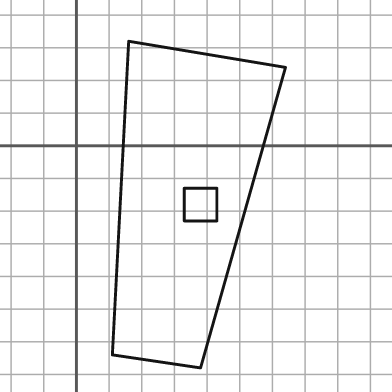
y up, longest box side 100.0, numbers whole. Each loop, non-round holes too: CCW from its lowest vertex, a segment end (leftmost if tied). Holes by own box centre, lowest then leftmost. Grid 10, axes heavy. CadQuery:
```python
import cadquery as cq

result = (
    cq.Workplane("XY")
    .moveTo(38.0, -68.0)
    .lineTo(64.0, 24.0)
    .lineTo(16.0, 32.0)
    .lineTo(11.0, -64.0)
    .close()
    .moveTo(33.0, -23.0)
    .lineTo(43.0, -23.0)
    .lineTo(43.0, -13.0)
    .lineTo(33.0, -13.0)
    .close()
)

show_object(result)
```